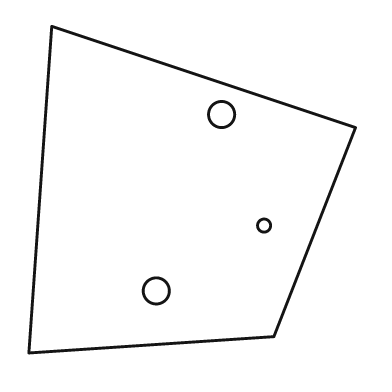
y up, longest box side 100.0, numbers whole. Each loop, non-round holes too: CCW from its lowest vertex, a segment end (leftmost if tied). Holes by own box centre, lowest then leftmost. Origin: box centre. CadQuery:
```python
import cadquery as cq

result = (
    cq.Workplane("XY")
    .moveTo(-50.0, -50.0)
    .lineTo(25.0, -45.0)
    .lineTo(50.0, 19.0)
    .lineTo(-43.0, 50.0)
    .close()
    .moveTo(-11.0, -31.0)
    .circle(4.0)
    .moveTo(22.0, -11.0)
    .circle(2.0)
    .moveTo(9.0, 23.0)
    .circle(4.0)
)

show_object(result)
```